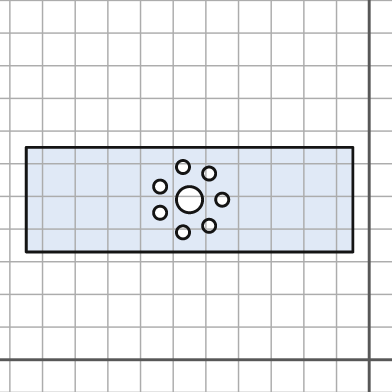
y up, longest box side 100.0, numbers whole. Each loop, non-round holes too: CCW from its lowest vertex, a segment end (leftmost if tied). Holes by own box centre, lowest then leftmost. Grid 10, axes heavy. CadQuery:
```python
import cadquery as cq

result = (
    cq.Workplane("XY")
    .moveTo(-105.0, 33.0)
    .lineTo(-5.0, 33.0)
    .lineTo(-5.0, 65.0)
    .lineTo(-105.0, 65.0)
    .close()
    .moveTo(-57.0, 39.0)
    .circle(2.0)
    .moveTo(-49.0, 41.0)
    .circle(2.0)
    .moveTo(-64.0, 45.0)
    .circle(2.0)
    .moveTo(-55.0, 49.0)
    .circle(4.0)
    .moveTo(-45.0, 49.0)
    .circle(2.0)
    .moveTo(-64.0, 53.0)
    .circle(2.0)
    .moveTo(-49.0, 57.0)
    .circle(2.0)
    .moveTo(-57.0, 59.0)
    .circle(2.0)
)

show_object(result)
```